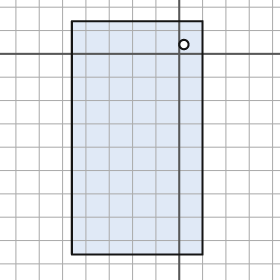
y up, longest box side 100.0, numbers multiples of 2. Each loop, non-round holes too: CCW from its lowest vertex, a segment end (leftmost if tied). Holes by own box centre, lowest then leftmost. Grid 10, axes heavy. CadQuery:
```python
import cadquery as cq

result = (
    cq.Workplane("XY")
    .moveTo(-46.0, -86.0)
    .lineTo(10.0, -86.0)
    .lineTo(10.0, 14.0)
    .lineTo(-46.0, 14.0)
    .close()
    .moveTo(2.0, 4.0)
    .circle(2.0)
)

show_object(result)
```